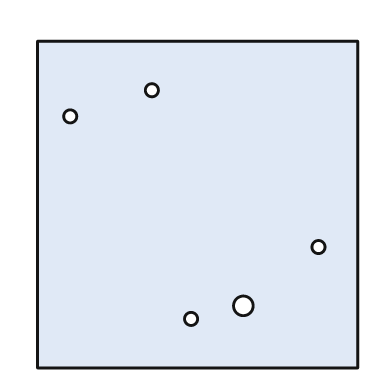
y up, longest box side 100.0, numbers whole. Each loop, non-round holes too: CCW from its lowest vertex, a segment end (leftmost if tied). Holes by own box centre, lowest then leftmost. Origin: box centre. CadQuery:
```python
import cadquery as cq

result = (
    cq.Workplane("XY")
    .moveTo(-49.0, -50.0)
    .lineTo(49.0, -50.0)
    .lineTo(49.0, 50.0)
    .lineTo(-49.0, 50.0)
    .close()
    .moveTo(-2.0, -35.0)
    .circle(2.0)
    .moveTo(14.0, -31.0)
    .circle(3.0)
    .moveTo(37.0, -13.0)
    .circle(2.0)
    .moveTo(-39.0, 27.0)
    .circle(2.0)
    .moveTo(-14.0, 35.0)
    .circle(2.0)
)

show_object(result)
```